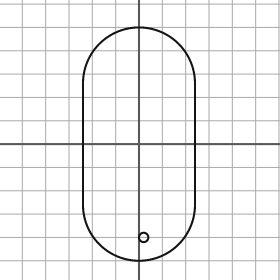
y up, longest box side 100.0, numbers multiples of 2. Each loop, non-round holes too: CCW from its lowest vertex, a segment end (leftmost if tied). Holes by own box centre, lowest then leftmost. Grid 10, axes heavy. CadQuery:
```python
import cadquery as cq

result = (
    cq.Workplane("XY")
    .moveTo(-24.0, -26.0)
    .threePointArc((0.0, -50.0), (24.0, -26.0))
    .lineTo(24.0, 26.0)
    .threePointArc((0.0, 50.0), (-24.0, 26.0))
    .close()
    .moveTo(2.0, -40.0)
    .circle(2.0)
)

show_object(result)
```